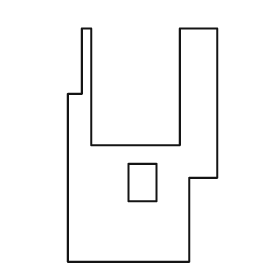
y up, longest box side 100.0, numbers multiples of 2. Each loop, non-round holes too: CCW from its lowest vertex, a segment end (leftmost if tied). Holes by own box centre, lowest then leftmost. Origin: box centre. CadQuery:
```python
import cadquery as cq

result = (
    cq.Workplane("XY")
    .moveTo(-32.0, -50.0)
    .lineTo(20.0, -50.0)
    .lineTo(20.0, -14.0)
    .lineTo(32.0, -14.0)
    .lineTo(32.0, 50.0)
    .lineTo(16.0, 50.0)
    .lineTo(16.0, 0.0)
    .lineTo(-22.0, 0.0)
    .lineTo(-22.0, 50.0)
    .lineTo(-26.0, 50.0)
    .lineTo(-26.0, 22.0)
    .lineTo(-32.0, 22.0)
    .close()
    .moveTo(-6.0, -24.0)
    .lineTo(6.0, -24.0)
    .lineTo(6.0, -8.0)
    .lineTo(-6.0, -8.0)
    .close()
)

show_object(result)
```